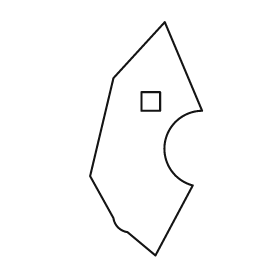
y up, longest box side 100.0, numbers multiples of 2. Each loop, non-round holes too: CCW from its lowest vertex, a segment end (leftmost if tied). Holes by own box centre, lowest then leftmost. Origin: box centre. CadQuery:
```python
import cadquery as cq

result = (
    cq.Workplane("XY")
    .moveTo(4.0, -50.0)
    .lineTo(20.0, -20.0)
    .threePointArc((8.0, -2.0), (24.0, 12.0))
    .lineTo(8.0, 50.0)
    .lineTo(-14.0, 26.0)
    .lineTo(-24.0, -16.0)
    .lineTo(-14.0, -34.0)
    .threePointArc((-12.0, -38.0), (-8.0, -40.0))
    .close()
    .moveTo(-2.0, 12.0)
    .lineTo(6.0, 12.0)
    .lineTo(6.0, 20.0)
    .lineTo(-2.0, 20.0)
    .close()
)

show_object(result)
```